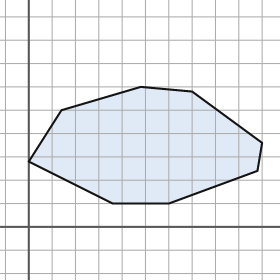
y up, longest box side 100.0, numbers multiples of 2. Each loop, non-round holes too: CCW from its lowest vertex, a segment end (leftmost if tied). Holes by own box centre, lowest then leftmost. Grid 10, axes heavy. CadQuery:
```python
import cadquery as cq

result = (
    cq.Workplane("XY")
    .moveTo(36.0, 10.0)
    .lineTo(60.0, 10.0)
    .lineTo(98.0, 24.0)
    .lineTo(100.0, 36.0)
    .lineTo(70.0, 58.0)
    .lineTo(48.0, 60.0)
    .lineTo(14.0, 50.0)
    .lineTo(0.0, 28.0)
    .close()
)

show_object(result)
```